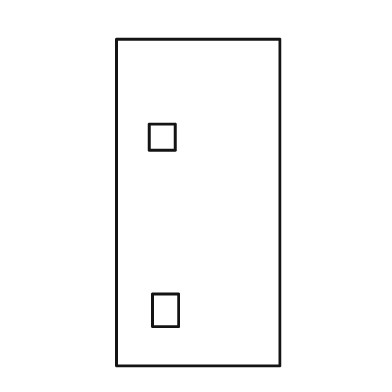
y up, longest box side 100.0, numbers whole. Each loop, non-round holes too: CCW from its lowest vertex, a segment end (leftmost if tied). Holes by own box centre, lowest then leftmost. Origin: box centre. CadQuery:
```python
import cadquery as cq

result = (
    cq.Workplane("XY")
    .moveTo(-25.0, -50.0)
    .lineTo(25.0, -50.0)
    .lineTo(25.0, 50.0)
    .lineTo(-25.0, 50.0)
    .close()
    .moveTo(-14.0, -38.0)
    .lineTo(-6.0, -38.0)
    .lineTo(-6.0, -28.0)
    .lineTo(-14.0, -28.0)
    .close()
    .moveTo(-15.0, 16.0)
    .lineTo(-7.0, 16.0)
    .lineTo(-7.0, 24.0)
    .lineTo(-15.0, 24.0)
    .close()
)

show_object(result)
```